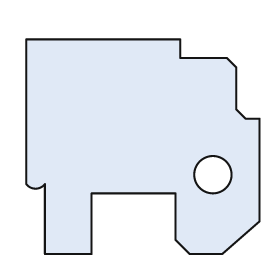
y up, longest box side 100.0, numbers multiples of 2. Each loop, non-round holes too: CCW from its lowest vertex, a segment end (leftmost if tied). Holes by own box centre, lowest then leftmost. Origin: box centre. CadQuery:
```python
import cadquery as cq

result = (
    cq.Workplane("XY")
    .moveTo(-42.0, -46.0)
    .lineTo(-22.0, -46.0)
    .lineTo(-22.0, -20.0)
    .lineTo(14.0, -20.0)
    .lineTo(14.0, -40.0)
    .lineTo(20.0, -46.0)
    .lineTo(34.0, -46.0)
    .lineTo(50.0, -32.0)
    .lineTo(50.0, 12.0)
    .lineTo(44.0, 12.0)
    .lineTo(40.0, 16.0)
    .lineTo(40.0, 34.0)
    .lineTo(36.0, 38.0)
    .lineTo(16.0, 38.0)
    .lineTo(16.0, 46.0)
    .lineTo(-50.0, 46.0)
    .lineTo(-50.0, -16.0)
    .threePointArc((-46.0, -18.0), (-42.0, -16.0))
    .close()
    .moveTo(30.0, -12.0)
    .circle(8.0)
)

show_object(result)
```